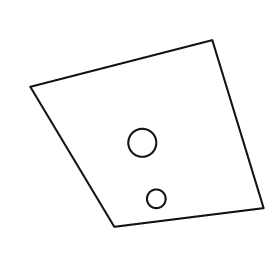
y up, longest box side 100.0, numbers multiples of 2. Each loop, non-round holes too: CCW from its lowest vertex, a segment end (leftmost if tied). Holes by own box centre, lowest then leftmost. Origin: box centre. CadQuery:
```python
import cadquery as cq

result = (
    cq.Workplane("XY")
    .moveTo(-14.0, -40.0)
    .lineTo(50.0, -32.0)
    .lineTo(28.0, 40.0)
    .lineTo(-50.0, 20.0)
    .close()
    .moveTo(4.0, -28.0)
    .circle(4.0)
    .moveTo(-2.0, -4.0)
    .circle(6.0)
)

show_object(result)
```